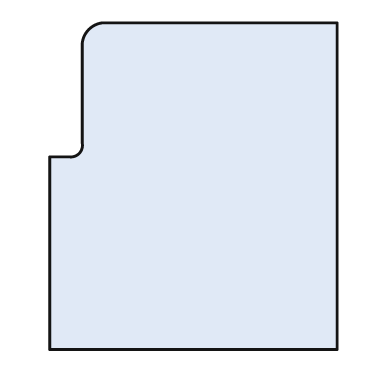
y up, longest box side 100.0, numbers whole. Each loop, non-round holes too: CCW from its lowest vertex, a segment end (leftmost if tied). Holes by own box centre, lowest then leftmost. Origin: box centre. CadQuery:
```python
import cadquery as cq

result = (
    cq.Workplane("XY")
    .moveTo(-44.0, -50.0)
    .lineTo(44.0, -50.0)
    .lineTo(44.0, 50.0)
    .lineTo(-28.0, 50.0)
    .threePointArc((-32.0, 48.0), (-34.0, 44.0))
    .lineTo(-34.0, 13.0)
    .threePointArc((-35.0, 10.0), (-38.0, 9.0))
    .lineTo(-44.0, 9.0)
    .close()
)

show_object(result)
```